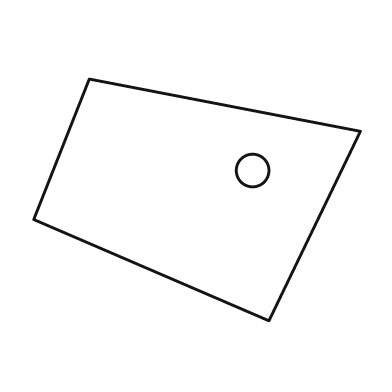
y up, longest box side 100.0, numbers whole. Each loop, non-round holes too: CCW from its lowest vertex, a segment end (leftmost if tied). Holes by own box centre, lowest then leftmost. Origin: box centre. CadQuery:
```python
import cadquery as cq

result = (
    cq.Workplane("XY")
    .moveTo(22.0, -37.0)
    .lineTo(50.0, 21.0)
    .lineTo(-33.0, 37.0)
    .lineTo(-50.0, -6.0)
    .close()
    .moveTo(17.0, 9.0)
    .circle(5.0)
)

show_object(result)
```